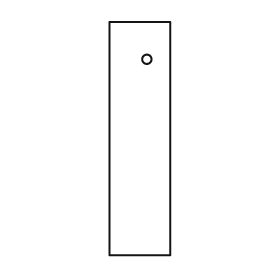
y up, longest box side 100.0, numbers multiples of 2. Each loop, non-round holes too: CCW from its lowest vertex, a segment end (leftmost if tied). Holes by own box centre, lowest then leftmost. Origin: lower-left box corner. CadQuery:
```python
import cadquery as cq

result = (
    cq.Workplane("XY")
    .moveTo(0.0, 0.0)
    .lineTo(26.0, 0.0)
    .lineTo(26.0, 100.0)
    .lineTo(0.0, 100.0)
    .close()
    .moveTo(16.0, 84.0)
    .circle(2.0)
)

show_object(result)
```